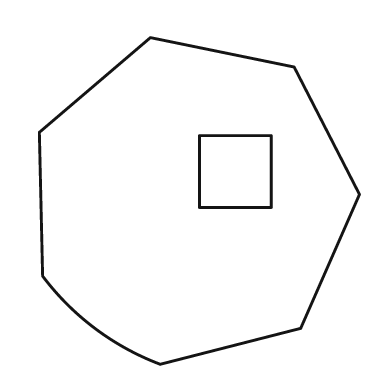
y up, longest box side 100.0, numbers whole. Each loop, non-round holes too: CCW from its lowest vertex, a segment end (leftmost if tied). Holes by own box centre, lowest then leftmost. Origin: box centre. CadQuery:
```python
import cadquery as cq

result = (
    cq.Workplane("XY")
    .moveTo(-12.0, -50.0)
    .lineTo(31.0, -39.0)
    .lineTo(49.0, 2.0)
    .lineTo(29.0, 41.0)
    .lineTo(-15.0, 50.0)
    .lineTo(-49.0, 21.0)
    .lineTo(-48.0, -23.0)
    .threePointArc((-32.0, -39.0), (-12.0, -50.0))
    .close()
    .moveTo(0.0, -2.0)
    .lineTo(22.0, -2.0)
    .lineTo(22.0, 20.0)
    .lineTo(0.0, 20.0)
    .close()
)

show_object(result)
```